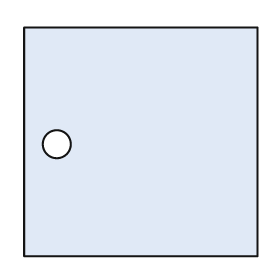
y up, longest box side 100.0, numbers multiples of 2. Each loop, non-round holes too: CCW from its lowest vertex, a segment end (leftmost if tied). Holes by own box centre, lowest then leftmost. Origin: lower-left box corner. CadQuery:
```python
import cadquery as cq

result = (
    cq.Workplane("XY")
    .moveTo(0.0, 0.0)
    .lineTo(100.0, 0.0)
    .lineTo(100.0, 98.0)
    .lineTo(0.0, 98.0)
    .close()
    .moveTo(14.0, 48.0)
    .circle(6.0)
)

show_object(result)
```